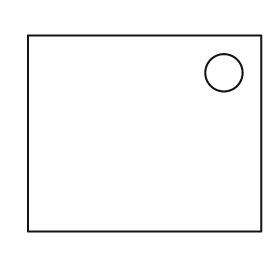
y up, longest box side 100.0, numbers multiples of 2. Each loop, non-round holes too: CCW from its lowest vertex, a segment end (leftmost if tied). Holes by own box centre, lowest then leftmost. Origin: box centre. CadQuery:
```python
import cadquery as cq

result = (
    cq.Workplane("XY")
    .moveTo(-50.0, -42.0)
    .lineTo(50.0, -42.0)
    .lineTo(50.0, 42.0)
    .lineTo(-50.0, 42.0)
    .close()
    .moveTo(34.0, 26.0)
    .circle(8.0)
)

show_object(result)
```